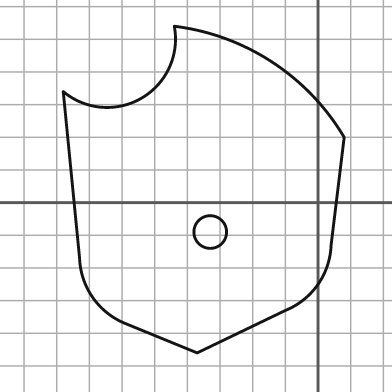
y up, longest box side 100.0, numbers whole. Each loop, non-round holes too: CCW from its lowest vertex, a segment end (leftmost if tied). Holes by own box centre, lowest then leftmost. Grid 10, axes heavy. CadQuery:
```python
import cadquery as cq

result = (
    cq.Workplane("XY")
    .moveTo(-37.0, -46.0)
    .lineTo(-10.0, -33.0)
    .threePointArc((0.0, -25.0), (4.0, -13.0))
    .lineTo(8.0, 20.0)
    .threePointArc((-14.0, 43.0), (-44.0, 54.0))
    .threePointArc((-54.0, 32.0), (-78.0, 34.0))
    .lineTo(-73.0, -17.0)
    .threePointArc((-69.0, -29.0), (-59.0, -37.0))
    .close()
    .moveTo(-33.0, -9.0)
    .circle(5.0)
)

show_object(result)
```